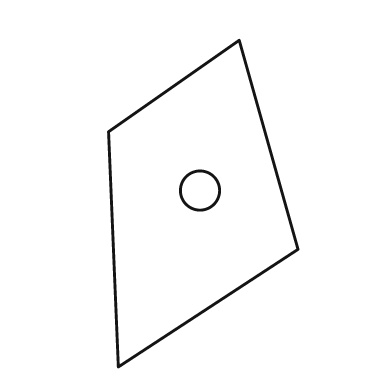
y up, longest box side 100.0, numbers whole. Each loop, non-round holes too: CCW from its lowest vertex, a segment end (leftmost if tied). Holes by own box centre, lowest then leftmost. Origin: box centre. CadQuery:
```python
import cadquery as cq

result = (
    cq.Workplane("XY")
    .moveTo(-26.0, -50.0)
    .lineTo(29.0, -14.0)
    .lineTo(11.0, 50.0)
    .lineTo(-29.0, 22.0)
    .close()
    .moveTo(-1.0, 4.0)
    .circle(6.0)
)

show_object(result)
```